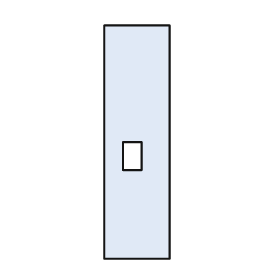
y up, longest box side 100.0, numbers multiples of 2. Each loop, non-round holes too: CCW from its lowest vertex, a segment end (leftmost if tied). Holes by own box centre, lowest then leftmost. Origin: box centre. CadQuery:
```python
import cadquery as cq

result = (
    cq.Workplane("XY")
    .moveTo(-14.0, -50.0)
    .lineTo(14.0, -50.0)
    .lineTo(14.0, 50.0)
    .lineTo(-14.0, 50.0)
    .close()
    .moveTo(-6.0, -12.0)
    .lineTo(2.0, -12.0)
    .lineTo(2.0, 0.0)
    .lineTo(-6.0, 0.0)
    .close()
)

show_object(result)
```